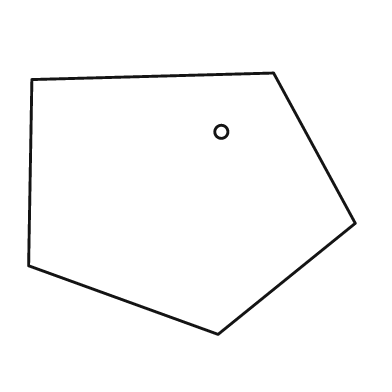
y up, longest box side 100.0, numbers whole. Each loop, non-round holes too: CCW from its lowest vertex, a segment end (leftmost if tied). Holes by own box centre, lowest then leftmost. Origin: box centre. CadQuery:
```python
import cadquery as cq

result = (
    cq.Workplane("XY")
    .moveTo(8.0, -40.0)
    .lineTo(50.0, -6.0)
    .lineTo(25.0, 40.0)
    .lineTo(-49.0, 38.0)
    .lineTo(-50.0, -19.0)
    .close()
    .moveTo(9.0, 22.0)
    .circle(2.0)
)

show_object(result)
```